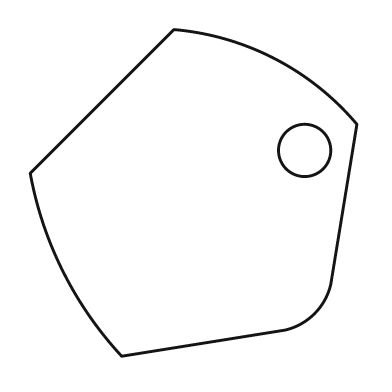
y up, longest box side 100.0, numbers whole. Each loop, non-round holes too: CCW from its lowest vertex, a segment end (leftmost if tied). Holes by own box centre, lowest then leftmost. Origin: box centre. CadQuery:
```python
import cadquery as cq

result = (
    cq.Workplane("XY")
    .moveTo(-22.0, -50.0)
    .lineTo(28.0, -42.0)
    .threePointArc((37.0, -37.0), (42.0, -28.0))
    .lineTo(50.0, 21.0)
    .threePointArc((25.0, 41.0), (-6.0, 50.0))
    .lineTo(-50.0, 6.0)
    .threePointArc((-40.0, -24.0), (-22.0, -50.0))
    .close()
    .moveTo(34.0, 13.0)
    .circle(8.0)
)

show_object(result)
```